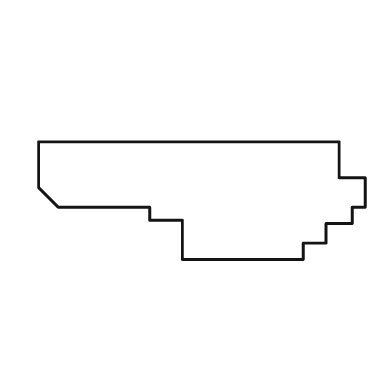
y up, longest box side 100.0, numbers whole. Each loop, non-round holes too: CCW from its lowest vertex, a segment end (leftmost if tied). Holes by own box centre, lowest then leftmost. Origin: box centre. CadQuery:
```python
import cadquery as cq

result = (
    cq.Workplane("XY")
    .moveTo(-6.0, -18.0)
    .lineTo(31.0, -18.0)
    .lineTo(31.0, -13.0)
    .lineTo(38.0, -13.0)
    .lineTo(38.0, -7.0)
    .lineTo(46.0, -7.0)
    .lineTo(46.0, -2.0)
    .lineTo(50.0, -2.0)
    .lineTo(50.0, 7.0)
    .lineTo(42.0, 7.0)
    .lineTo(42.0, 18.0)
    .lineTo(-50.0, 18.0)
    .lineTo(-50.0, 4.0)
    .lineTo(-44.0, -2.0)
    .lineTo(-16.0, -2.0)
    .lineTo(-16.0, -6.0)
    .lineTo(-6.0, -6.0)
    .close()
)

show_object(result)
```